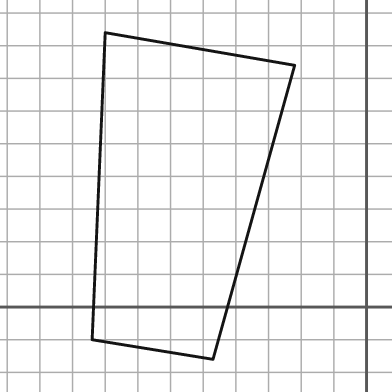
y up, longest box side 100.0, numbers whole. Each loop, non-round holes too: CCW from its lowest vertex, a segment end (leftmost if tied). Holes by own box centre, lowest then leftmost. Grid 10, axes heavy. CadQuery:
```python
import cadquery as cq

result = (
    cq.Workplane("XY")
    .moveTo(-47.0, -16.0)
    .lineTo(-22.0, 74.0)
    .lineTo(-80.0, 84.0)
    .lineTo(-84.0, -10.0)
    .close()
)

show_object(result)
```